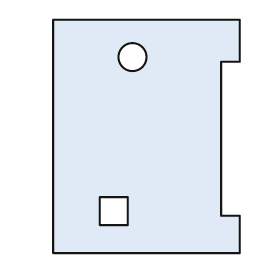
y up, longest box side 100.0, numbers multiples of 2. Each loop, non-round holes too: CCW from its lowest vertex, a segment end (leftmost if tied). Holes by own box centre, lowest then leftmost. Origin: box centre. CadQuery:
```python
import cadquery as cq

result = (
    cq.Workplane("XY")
    .moveTo(-40.0, -50.0)
    .lineTo(40.0, -50.0)
    .lineTo(40.0, -34.0)
    .lineTo(32.0, -34.0)
    .lineTo(32.0, 32.0)
    .lineTo(40.0, 32.0)
    .lineTo(40.0, 50.0)
    .lineTo(-40.0, 50.0)
    .close()
    .moveTo(-20.0, -38.0)
    .lineTo(-8.0, -38.0)
    .lineTo(-8.0, -26.0)
    .lineTo(-20.0, -26.0)
    .close()
    .moveTo(-6.0, 34.0)
    .circle(6.0)
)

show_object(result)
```